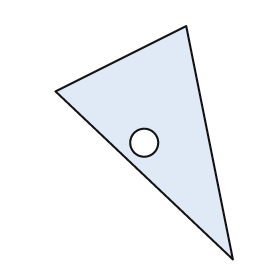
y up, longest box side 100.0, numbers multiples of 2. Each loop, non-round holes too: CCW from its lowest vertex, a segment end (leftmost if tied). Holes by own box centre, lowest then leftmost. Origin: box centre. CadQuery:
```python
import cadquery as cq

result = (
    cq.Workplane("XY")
    .moveTo(38.0, -50.0)
    .lineTo(18.0, 50.0)
    .lineTo(-38.0, 22.0)
    .close()
    .moveTo(0.0, 0.0)
    .circle(6.0)
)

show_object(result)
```